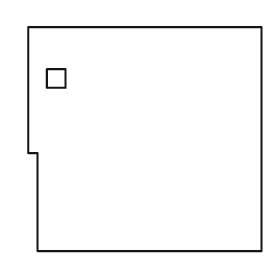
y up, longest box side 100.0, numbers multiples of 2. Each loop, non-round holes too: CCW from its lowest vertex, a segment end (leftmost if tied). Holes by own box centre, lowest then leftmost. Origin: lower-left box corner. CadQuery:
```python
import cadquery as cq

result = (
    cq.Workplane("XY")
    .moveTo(4.0, 0.0)
    .lineTo(100.0, 0.0)
    .lineTo(100.0, 96.0)
    .lineTo(0.0, 96.0)
    .lineTo(0.0, 42.0)
    .lineTo(4.0, 42.0)
    .close()
    .moveTo(8.0, 70.0)
    .lineTo(16.0, 70.0)
    .lineTo(16.0, 78.0)
    .lineTo(8.0, 78.0)
    .close()
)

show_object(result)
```